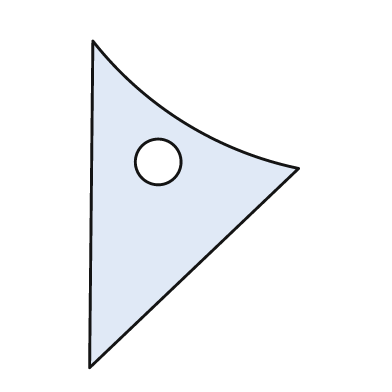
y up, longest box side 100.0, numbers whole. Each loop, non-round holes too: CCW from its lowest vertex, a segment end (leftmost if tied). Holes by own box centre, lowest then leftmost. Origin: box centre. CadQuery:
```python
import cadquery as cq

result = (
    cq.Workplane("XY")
    .moveTo(-32.0, -50.0)
    .lineTo(32.0, 11.0)
    .threePointArc((-3.0, 25.0), (-31.0, 50.0))
    .close()
    .moveTo(-11.0, 13.0)
    .circle(7.0)
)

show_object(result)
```